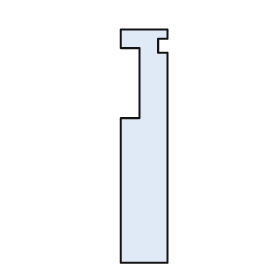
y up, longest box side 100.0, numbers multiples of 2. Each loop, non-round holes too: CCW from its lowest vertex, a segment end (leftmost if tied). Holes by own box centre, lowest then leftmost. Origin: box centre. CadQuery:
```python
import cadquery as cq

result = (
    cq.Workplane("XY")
    .moveTo(-10.0, -50.0)
    .lineTo(10.0, -50.0)
    .lineTo(10.0, 40.0)
    .lineTo(6.0, 40.0)
    .lineTo(6.0, 46.0)
    .lineTo(10.0, 46.0)
    .lineTo(10.0, 50.0)
    .lineTo(-10.0, 50.0)
    .lineTo(-10.0, 42.0)
    .lineTo(-2.0, 42.0)
    .lineTo(-2.0, 12.0)
    .lineTo(-10.0, 12.0)
    .close()
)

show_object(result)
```